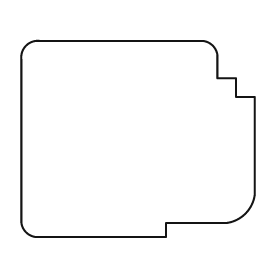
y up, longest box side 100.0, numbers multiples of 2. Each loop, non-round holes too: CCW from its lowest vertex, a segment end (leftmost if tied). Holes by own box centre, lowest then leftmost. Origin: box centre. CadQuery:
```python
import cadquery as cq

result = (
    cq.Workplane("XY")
    .moveTo(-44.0, -42.0)
    .lineTo(12.0, -42.0)
    .lineTo(12.0, -36.0)
    .lineTo(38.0, -36.0)
    .threePointArc((46.0, -32.0), (50.0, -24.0))
    .lineTo(50.0, 18.0)
    .lineTo(42.0, 18.0)
    .lineTo(42.0, 26.0)
    .lineTo(34.0, 26.0)
    .lineTo(34.0, 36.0)
    .threePointArc((32.0, 40.0), (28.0, 42.0))
    .lineTo(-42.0, 42.0)
    .threePointArc((-48.0, 40.0), (-50.0, 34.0))
    .lineTo(-50.0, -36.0)
    .threePointArc((-48.0, -40.0), (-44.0, -42.0))
    .close()
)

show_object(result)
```